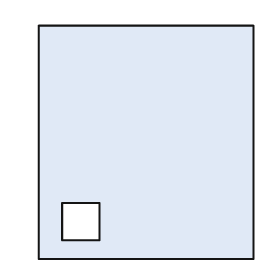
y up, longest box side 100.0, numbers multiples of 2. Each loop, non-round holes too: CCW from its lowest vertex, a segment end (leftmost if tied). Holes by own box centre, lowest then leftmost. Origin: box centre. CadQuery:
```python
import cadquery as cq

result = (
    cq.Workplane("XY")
    .moveTo(-46.0, -50.0)
    .lineTo(46.0, -50.0)
    .lineTo(46.0, 50.0)
    .lineTo(-46.0, 50.0)
    .close()
    .moveTo(-36.0, -42.0)
    .lineTo(-20.0, -42.0)
    .lineTo(-20.0, -26.0)
    .lineTo(-36.0, -26.0)
    .close()
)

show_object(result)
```